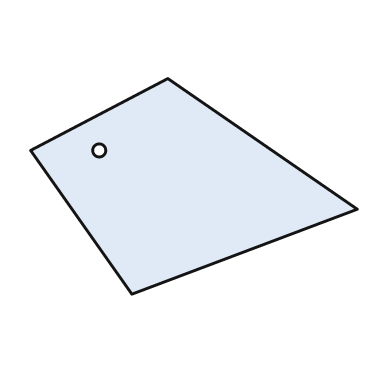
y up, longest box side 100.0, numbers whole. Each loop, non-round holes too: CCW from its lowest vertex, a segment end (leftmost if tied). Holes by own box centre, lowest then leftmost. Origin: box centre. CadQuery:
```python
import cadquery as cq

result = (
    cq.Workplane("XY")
    .moveTo(-19.0, -33.0)
    .lineTo(50.0, -7.0)
    .lineTo(-8.0, 33.0)
    .lineTo(-50.0, 11.0)
    .close()
    .moveTo(-29.0, 11.0)
    .circle(2.0)
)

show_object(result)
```